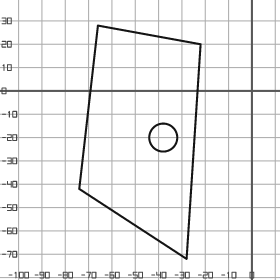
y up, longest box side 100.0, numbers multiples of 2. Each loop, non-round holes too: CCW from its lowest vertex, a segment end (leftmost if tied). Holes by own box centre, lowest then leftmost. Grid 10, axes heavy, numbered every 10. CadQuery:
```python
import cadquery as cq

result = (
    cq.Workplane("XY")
    .moveTo(-28.0, -72.0)
    .lineTo(-22.0, 20.0)
    .lineTo(-66.0, 28.0)
    .lineTo(-74.0, -42.0)
    .close()
    .moveTo(-38.0, -20.0)
    .circle(6.0)
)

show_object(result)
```